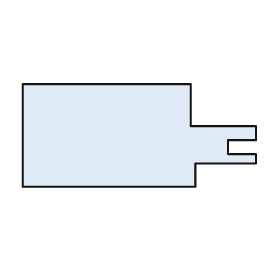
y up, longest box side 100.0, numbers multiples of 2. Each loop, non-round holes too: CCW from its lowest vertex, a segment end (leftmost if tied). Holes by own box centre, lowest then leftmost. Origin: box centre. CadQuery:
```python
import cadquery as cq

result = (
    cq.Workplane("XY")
    .moveTo(-50.0, -22.0)
    .lineTo(24.0, -22.0)
    .lineTo(24.0, -12.0)
    .lineTo(50.0, -12.0)
    .lineTo(50.0, -8.0)
    .lineTo(38.0, -8.0)
    .lineTo(38.0, -2.0)
    .lineTo(50.0, -2.0)
    .lineTo(50.0, 4.0)
    .lineTo(22.0, 4.0)
    .lineTo(22.0, 22.0)
    .lineTo(-50.0, 22.0)
    .close()
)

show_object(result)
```